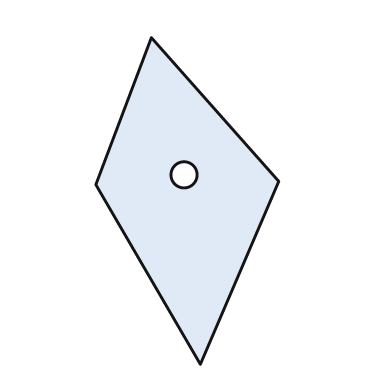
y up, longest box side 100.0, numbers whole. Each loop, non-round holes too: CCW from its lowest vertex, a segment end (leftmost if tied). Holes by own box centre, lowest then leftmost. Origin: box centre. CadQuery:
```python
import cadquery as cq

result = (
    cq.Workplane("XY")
    .moveTo(4.0, -50.0)
    .lineTo(28.0, 6.0)
    .lineTo(-11.0, 50.0)
    .lineTo(-28.0, 5.0)
    .close()
    .moveTo(-1.0, 8.0)
    .circle(4.0)
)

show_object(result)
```